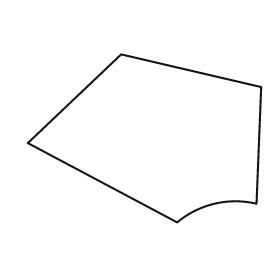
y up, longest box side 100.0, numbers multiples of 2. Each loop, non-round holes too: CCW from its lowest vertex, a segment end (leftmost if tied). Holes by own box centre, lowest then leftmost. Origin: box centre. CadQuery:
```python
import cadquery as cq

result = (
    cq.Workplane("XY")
    .moveTo(14.0, -36.0)
    .threePointArc((30.0, -28.0), (48.0, -28.0))
    .lineTo(50.0, 22.0)
    .lineTo(-10.0, 36.0)
    .lineTo(-50.0, -2.0)
    .close()
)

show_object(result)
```